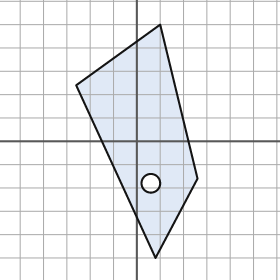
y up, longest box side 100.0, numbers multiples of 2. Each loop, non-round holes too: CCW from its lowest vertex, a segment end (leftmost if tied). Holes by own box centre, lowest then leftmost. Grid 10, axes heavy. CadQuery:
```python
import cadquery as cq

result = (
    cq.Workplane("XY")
    .moveTo(8.0, -50.0)
    .lineTo(26.0, -16.0)
    .lineTo(10.0, 50.0)
    .lineTo(-26.0, 24.0)
    .close()
    .moveTo(6.0, -18.0)
    .circle(4.0)
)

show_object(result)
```